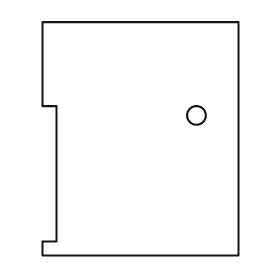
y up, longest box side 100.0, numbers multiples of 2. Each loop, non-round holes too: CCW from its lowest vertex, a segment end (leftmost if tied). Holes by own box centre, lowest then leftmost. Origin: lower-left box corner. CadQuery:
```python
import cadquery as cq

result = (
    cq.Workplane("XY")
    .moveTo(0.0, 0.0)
    .lineTo(84.0, 0.0)
    .lineTo(84.0, 100.0)
    .lineTo(0.0, 100.0)
    .lineTo(0.0, 64.0)
    .lineTo(6.0, 64.0)
    .lineTo(6.0, 6.0)
    .lineTo(0.0, 6.0)
    .close()
    .moveTo(66.0, 60.0)
    .circle(4.0)
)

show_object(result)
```